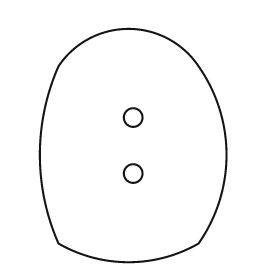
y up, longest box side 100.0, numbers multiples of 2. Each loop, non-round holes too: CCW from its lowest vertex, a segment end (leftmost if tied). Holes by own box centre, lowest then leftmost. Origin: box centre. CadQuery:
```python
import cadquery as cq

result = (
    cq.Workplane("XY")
    .moveTo(-32.0, -42.0)
    .threePointArc((-2.0, -50.0), (28.0, -42.0))
    .threePointArc((40.0, -4.0), (28.0, 34.0))
    .threePointArc((-2.0, 50.0), (-32.0, 34.0))
    .threePointArc((-40.0, -4.0), (-32.0, -42.0))
    .close()
    .moveTo(0.0, -12.0)
    .circle(4.0)
    .moveTo(0.0, 12.0)
    .circle(4.0)
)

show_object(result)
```